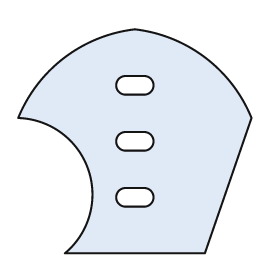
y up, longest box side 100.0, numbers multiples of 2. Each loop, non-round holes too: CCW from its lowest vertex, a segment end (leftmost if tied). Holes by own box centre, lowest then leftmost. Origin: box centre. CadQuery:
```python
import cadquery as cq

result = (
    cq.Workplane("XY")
    .moveTo(-30.0, -48.0)
    .lineTo(30.0, -48.0)
    .lineTo(50.0, 10.0)
    .threePointArc((30.0, 36.0), (0.0, 48.0))
    .threePointArc((-30.0, 36.0), (-50.0, 10.0))
    .threePointArc((-20.0, -12.0), (-30.0, -48.0))
    .close()
    .moveTo(-4.0, -28.0)
    .lineTo(4.0, -28.0)
    .threePointArc((8.0, -24.0), (4.0, -20.0))
    .lineTo(-4.0, -20.0)
    .threePointArc((-8.0, -24.0), (-4.0, -28.0))
    .close()
    .moveTo(-4.0, -4.0)
    .lineTo(4.0, -4.0)
    .threePointArc((8.0, 0.0), (4.0, 4.0))
    .lineTo(-4.0, 4.0)
    .threePointArc((-8.0, 0.0), (-4.0, -4.0))
    .close()
    .moveTo(-4.0, 20.0)
    .lineTo(4.0, 20.0)
    .threePointArc((8.0, 24.0), (4.0, 28.0))
    .lineTo(-4.0, 28.0)
    .threePointArc((-8.0, 24.0), (-4.0, 20.0))
    .close()
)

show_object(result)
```